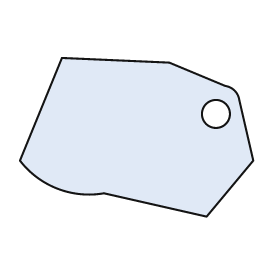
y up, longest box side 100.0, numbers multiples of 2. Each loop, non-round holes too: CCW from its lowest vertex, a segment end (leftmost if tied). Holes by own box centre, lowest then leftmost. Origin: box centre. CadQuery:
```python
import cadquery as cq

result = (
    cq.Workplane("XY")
    .moveTo(30.0, -34.0)
    .lineTo(50.0, -10.0)
    .lineTo(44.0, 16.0)
    .threePointArc((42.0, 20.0), (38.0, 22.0))
    .lineTo(14.0, 32.0)
    .lineTo(-32.0, 34.0)
    .lineTo(-50.0, -10.0)
    .threePointArc((-34.0, -22.0), (-14.0, -24.0))
    .close()
    .moveTo(34.0, 10.0)
    .circle(6.0)
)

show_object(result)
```